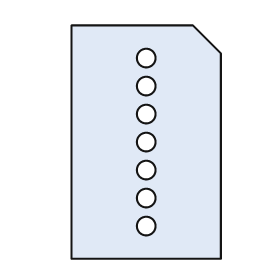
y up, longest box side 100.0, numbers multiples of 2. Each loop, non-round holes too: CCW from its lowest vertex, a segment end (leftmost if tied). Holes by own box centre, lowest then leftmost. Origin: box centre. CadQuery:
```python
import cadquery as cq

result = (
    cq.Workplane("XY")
    .moveTo(-32.0, -50.0)
    .lineTo(32.0, -50.0)
    .lineTo(32.0, 38.0)
    .lineTo(20.0, 50.0)
    .lineTo(-32.0, 50.0)
    .close()
    .moveTo(0.0, -36.0)
    .circle(4.0)
    .moveTo(0.0, -24.0)
    .circle(4.0)
    .moveTo(0.0, -12.0)
    .circle(4.0)
    .moveTo(0.0, 0.0)
    .circle(4.0)
    .moveTo(0.0, 12.0)
    .circle(4.0)
    .moveTo(0.0, 24.0)
    .circle(4.0)
    .moveTo(0.0, 36.0)
    .circle(4.0)
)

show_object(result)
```